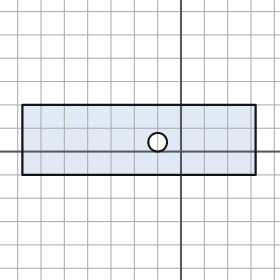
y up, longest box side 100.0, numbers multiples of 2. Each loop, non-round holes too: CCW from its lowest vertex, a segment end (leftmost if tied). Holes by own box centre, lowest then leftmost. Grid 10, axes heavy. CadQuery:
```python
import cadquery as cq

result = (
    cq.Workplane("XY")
    .moveTo(-68.0, -10.0)
    .lineTo(32.0, -10.0)
    .lineTo(32.0, 20.0)
    .lineTo(-68.0, 20.0)
    .close()
    .moveTo(-10.0, 4.0)
    .circle(4.0)
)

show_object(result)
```